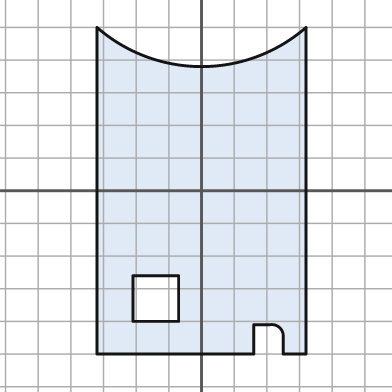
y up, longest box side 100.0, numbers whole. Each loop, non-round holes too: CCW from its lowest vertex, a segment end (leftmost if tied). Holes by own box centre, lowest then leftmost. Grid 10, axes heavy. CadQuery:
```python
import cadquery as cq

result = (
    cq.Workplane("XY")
    .moveTo(-32.0, -50.0)
    .lineTo(16.0, -50.0)
    .lineTo(16.0, -41.0)
    .lineTo(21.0, -41.0)
    .threePointArc((24.0, -42.0), (25.0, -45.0))
    .lineTo(25.0, -50.0)
    .lineTo(32.0, -50.0)
    .lineTo(32.0, 50.0)
    .threePointArc((0.0, 38.0), (-32.0, 50.0))
    .close()
    .moveTo(-21.0, -40.0)
    .lineTo(-7.0, -40.0)
    .lineTo(-7.0, -26.0)
    .lineTo(-21.0, -26.0)
    .close()
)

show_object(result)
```